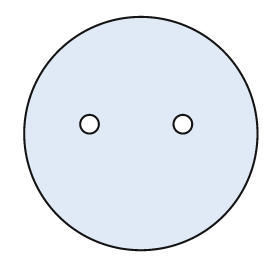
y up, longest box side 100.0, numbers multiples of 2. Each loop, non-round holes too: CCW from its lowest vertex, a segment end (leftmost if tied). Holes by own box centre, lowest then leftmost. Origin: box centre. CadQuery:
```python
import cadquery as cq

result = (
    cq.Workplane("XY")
    .moveTo(0.0, 0.0)
    .circle(50.0)
    .moveTo(-22.0, 4.0)
    .circle(4.0)
    .moveTo(18.0, 4.0)
    .circle(4.0)
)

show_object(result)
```